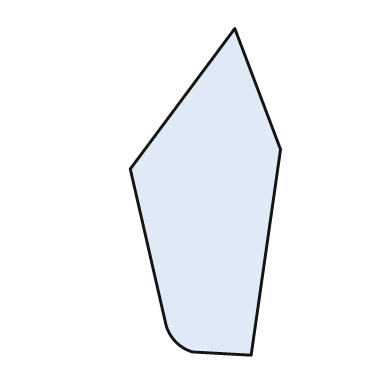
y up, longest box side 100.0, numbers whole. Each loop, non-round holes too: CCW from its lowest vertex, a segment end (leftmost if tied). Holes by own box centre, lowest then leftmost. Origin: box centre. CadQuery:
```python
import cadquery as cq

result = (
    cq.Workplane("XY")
    .moveTo(14.0, -50.0)
    .lineTo(23.0, 13.0)
    .lineTo(9.0, 50.0)
    .lineTo(-23.0, 7.0)
    .lineTo(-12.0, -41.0)
    .threePointArc((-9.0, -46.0), (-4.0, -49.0))
    .close()
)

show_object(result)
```